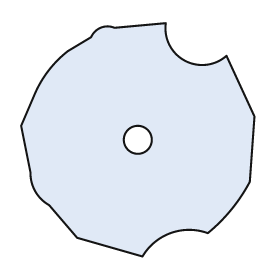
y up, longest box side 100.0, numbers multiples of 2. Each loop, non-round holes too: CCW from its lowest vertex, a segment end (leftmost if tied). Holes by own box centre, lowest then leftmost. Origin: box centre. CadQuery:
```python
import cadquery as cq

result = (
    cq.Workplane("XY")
    .moveTo(2.0, -50.0)
    .threePointArc((14.0, -40.0), (30.0, -40.0))
    .threePointArc((40.0, -30.0), (48.0, -18.0))
    .lineTo(50.0, 10.0)
    .lineTo(38.0, 36.0)
    .threePointArc((20.0, 34.0), (12.0, 50.0))
    .lineTo(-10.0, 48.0)
    .threePointArc((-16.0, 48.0), (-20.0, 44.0))
    .lineTo(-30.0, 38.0)
    .threePointArc((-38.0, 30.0), (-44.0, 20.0))
    .lineTo(-50.0, 6.0)
    .lineTo(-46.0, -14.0)
    .threePointArc((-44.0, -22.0), (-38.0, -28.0))
    .lineTo(-26.0, -42.0)
    .close()
    .moveTo(0.0, 0.0)
    .circle(6.0)
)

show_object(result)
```